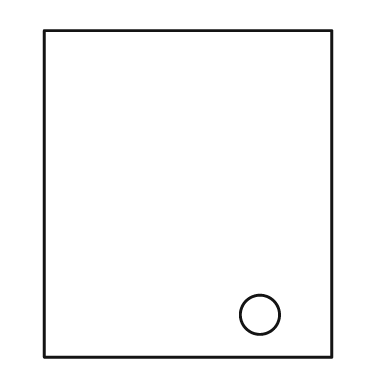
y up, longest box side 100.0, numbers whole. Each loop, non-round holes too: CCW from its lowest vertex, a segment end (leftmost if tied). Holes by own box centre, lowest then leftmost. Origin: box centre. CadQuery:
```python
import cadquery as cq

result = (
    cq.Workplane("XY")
    .moveTo(-44.0, -50.0)
    .lineTo(44.0, -50.0)
    .lineTo(44.0, 50.0)
    .lineTo(-44.0, 50.0)
    .close()
    .moveTo(22.0, -37.0)
    .circle(6.0)
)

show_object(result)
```